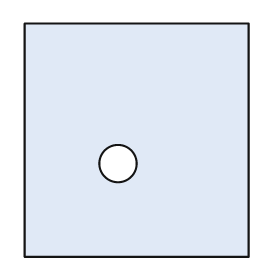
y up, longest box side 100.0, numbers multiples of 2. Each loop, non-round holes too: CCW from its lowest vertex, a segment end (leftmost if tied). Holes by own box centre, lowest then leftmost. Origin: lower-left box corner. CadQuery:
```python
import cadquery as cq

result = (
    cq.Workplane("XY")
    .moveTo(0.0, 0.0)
    .lineTo(96.0, 0.0)
    .lineTo(96.0, 100.0)
    .lineTo(0.0, 100.0)
    .close()
    .moveTo(40.0, 40.0)
    .circle(8.0)
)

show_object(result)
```